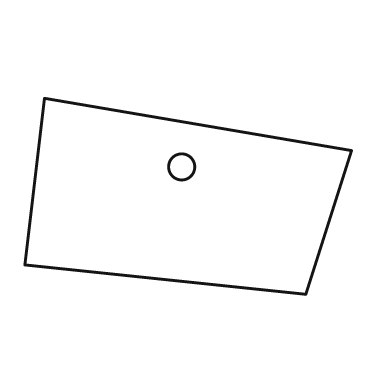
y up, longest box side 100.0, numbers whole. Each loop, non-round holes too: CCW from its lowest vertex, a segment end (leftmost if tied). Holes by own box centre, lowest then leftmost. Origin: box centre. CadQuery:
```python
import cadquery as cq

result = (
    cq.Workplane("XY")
    .moveTo(36.0, -30.0)
    .lineTo(50.0, 14.0)
    .lineTo(-44.0, 30.0)
    .lineTo(-50.0, -21.0)
    .close()
    .moveTo(-2.0, 9.0)
    .circle(4.0)
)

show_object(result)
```